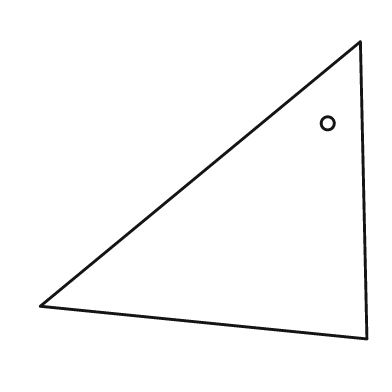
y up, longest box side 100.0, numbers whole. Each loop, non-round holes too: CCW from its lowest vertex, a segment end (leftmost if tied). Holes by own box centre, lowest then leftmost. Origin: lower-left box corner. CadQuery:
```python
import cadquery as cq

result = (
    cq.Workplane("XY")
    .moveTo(100.0, 0.0)
    .lineTo(98.0, 91.0)
    .lineTo(0.0, 10.0)
    .close()
    .moveTo(88.0, 66.0)
    .circle(2.0)
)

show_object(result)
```